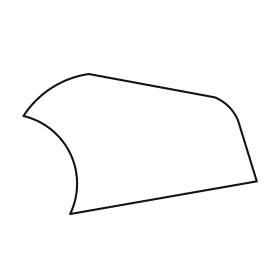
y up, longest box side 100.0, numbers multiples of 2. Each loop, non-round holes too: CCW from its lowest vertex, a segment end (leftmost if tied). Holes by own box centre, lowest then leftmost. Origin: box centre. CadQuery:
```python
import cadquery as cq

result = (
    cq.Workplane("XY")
    .moveTo(-30.0, -30.0)
    .lineTo(50.0, -16.0)
    .lineTo(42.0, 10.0)
    .threePointArc((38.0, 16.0), (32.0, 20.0))
    .lineTo(-22.0, 30.0)
    .threePointArc((-38.0, 24.0), (-50.0, 12.0))
    .threePointArc((-30.0, -4.0), (-30.0, -30.0))
    .close()
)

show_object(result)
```